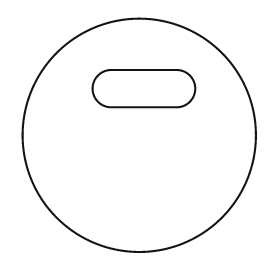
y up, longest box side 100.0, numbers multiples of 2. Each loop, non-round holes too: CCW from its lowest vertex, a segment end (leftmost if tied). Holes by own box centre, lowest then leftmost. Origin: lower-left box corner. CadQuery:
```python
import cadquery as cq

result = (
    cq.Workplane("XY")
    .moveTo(50.0, 50.0)
    .circle(50.0)
    .moveTo(38.0, 62.0)
    .lineTo(66.0, 62.0)
    .threePointArc((74.0, 70.0), (66.0, 78.0))
    .lineTo(38.0, 78.0)
    .threePointArc((30.0, 70.0), (38.0, 62.0))
    .close()
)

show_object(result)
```